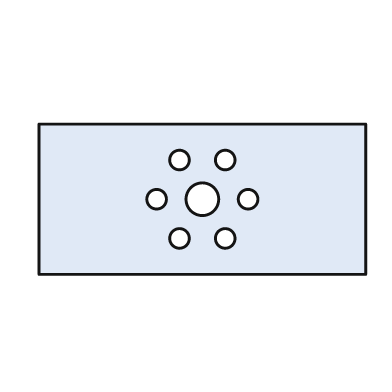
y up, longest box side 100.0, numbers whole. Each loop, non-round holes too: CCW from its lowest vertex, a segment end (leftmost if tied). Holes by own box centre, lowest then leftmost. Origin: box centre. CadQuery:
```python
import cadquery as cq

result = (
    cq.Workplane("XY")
    .moveTo(-50.0, -23.0)
    .lineTo(50.0, -23.0)
    .lineTo(50.0, 23.0)
    .lineTo(-50.0, 23.0)
    .close()
    .moveTo(-7.0, -12.0)
    .circle(3.0)
    .moveTo(7.0, -12.0)
    .circle(3.0)
    .moveTo(-14.0, 0.0)
    .circle(3.0)
    .moveTo(0.0, 0.0)
    .circle(5.0)
    .moveTo(14.0, 0.0)
    .circle(3.0)
    .moveTo(-7.0, 12.0)
    .circle(3.0)
    .moveTo(7.0, 12.0)
    .circle(3.0)
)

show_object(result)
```